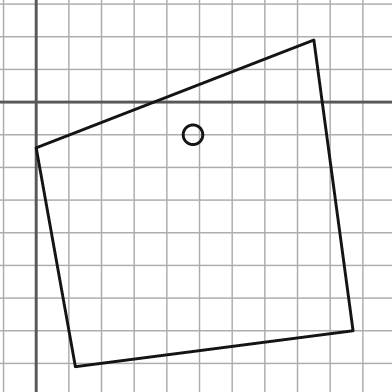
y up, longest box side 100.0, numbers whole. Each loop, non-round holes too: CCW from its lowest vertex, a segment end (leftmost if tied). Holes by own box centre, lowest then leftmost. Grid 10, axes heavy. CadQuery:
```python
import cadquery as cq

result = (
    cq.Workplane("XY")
    .moveTo(12.0, -81.0)
    .lineTo(97.0, -70.0)
    .lineTo(85.0, 19.0)
    .lineTo(0.0, -14.0)
    .close()
    .moveTo(48.0, -10.0)
    .circle(3.0)
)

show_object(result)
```